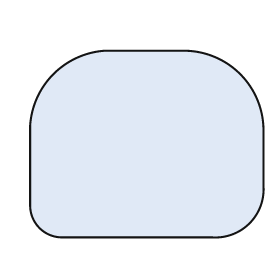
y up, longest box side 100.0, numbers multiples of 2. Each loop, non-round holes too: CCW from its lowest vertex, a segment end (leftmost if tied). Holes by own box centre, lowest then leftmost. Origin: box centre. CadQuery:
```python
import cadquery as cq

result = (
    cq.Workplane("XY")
    .moveTo(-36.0, -40.0)
    .lineTo(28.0, -40.0)
    .threePointArc((44.0, -34.0), (50.0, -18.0))
    .lineTo(50.0, 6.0)
    .threePointArc((40.0, 30.0), (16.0, 40.0))
    .lineTo(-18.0, 40.0)
    .threePointArc((-40.0, 30.0), (-50.0, 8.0))
    .lineTo(-50.0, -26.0)
    .threePointArc((-46.0, -36.0), (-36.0, -40.0))
    .close()
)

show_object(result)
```